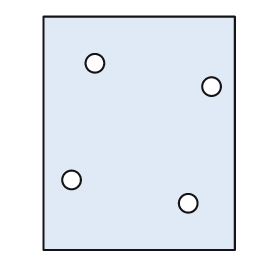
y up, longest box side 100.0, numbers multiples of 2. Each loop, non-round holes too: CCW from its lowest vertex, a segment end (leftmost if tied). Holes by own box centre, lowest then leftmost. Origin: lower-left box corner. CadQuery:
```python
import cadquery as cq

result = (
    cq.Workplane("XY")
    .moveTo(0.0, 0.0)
    .lineTo(82.0, 0.0)
    .lineTo(82.0, 100.0)
    .lineTo(0.0, 100.0)
    .close()
    .moveTo(62.0, 20.0)
    .circle(4.0)
    .moveTo(12.0, 30.0)
    .circle(4.0)
    .moveTo(72.0, 70.0)
    .circle(4.0)
    .moveTo(22.0, 80.0)
    .circle(4.0)
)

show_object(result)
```